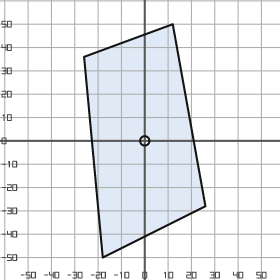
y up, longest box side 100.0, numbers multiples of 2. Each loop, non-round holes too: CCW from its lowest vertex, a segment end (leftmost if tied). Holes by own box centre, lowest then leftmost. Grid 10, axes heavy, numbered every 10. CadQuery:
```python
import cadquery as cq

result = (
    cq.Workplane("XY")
    .moveTo(-18.0, -50.0)
    .lineTo(26.0, -28.0)
    .lineTo(12.0, 50.0)
    .lineTo(-26.0, 36.0)
    .close()
    .moveTo(0.0, 0.0)
    .circle(2.0)
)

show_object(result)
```